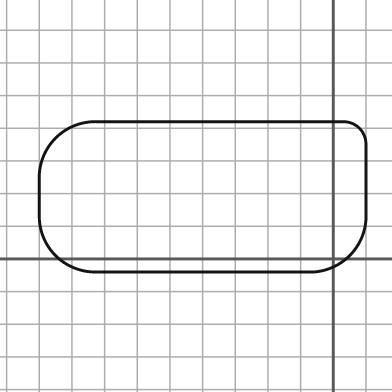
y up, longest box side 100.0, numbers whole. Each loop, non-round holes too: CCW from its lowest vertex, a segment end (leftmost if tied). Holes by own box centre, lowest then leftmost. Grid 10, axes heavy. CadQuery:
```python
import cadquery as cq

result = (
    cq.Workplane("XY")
    .moveTo(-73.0, -4.0)
    .lineTo(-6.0, -4.0)
    .threePointArc((5.0, 1.0), (10.0, 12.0))
    .lineTo(10.0, 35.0)
    .threePointArc((8.0, 40.0), (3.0, 42.0))
    .lineTo(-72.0, 42.0)
    .threePointArc((-85.0, 37.0), (-90.0, 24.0))
    .lineTo(-90.0, 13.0)
    .threePointArc((-85.0, 1.0), (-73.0, -4.0))
    .close()
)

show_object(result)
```